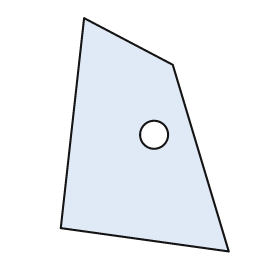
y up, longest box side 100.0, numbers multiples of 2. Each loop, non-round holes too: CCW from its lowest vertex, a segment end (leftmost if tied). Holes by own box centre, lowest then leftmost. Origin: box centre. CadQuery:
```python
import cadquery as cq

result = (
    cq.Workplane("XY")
    .moveTo(36.0, -50.0)
    .lineTo(12.0, 30.0)
    .lineTo(-26.0, 50.0)
    .lineTo(-36.0, -40.0)
    .close()
    .moveTo(4.0, 0.0)
    .circle(6.0)
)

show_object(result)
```